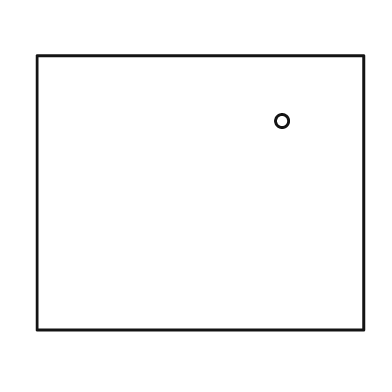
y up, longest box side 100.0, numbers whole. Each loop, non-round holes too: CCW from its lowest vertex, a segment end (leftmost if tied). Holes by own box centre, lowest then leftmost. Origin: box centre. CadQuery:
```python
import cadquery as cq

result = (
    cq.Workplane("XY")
    .moveTo(-50.0, -42.0)
    .lineTo(50.0, -42.0)
    .lineTo(50.0, 42.0)
    .lineTo(-50.0, 42.0)
    .close()
    .moveTo(25.0, 22.0)
    .circle(2.0)
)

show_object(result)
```